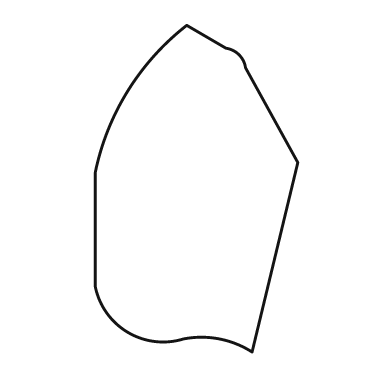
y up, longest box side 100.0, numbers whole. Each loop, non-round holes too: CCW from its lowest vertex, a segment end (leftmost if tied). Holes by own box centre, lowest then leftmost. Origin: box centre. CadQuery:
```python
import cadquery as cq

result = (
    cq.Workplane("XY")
    .moveTo(17.0, -50.0)
    .lineTo(31.0, 8.0)
    .lineTo(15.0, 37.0)
    .threePointArc((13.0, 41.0), (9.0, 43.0))
    .lineTo(-3.0, 50.0)
    .threePointArc((-21.0, 30.0), (-31.0, 5.0))
    .lineTo(-31.0, -30.0)
    .threePointArc((-21.0, -44.0), (-4.0, -46.0))
    .threePointArc((7.0, -46.0), (17.0, -50.0))
    .close()
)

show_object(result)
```